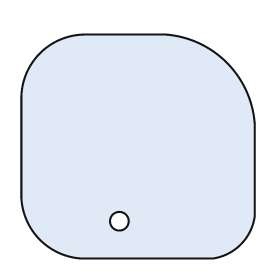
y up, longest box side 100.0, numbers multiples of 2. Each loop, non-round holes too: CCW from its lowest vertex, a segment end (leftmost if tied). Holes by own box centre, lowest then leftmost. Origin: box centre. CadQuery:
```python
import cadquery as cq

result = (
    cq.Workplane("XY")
    .moveTo(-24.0, -48.0)
    .lineTo(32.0, -48.0)
    .threePointArc((44.0, -42.0), (50.0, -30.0))
    .lineTo(50.0, 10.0)
    .threePointArc((38.0, 36.0), (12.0, 48.0))
    .lineTo(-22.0, 48.0)
    .threePointArc((-42.0, 40.0), (-50.0, 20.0))
    .lineTo(-50.0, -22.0)
    .threePointArc((-42.0, -40.0), (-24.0, -48.0))
    .close()
    .moveTo(-8.0, -32.0)
    .circle(4.0)
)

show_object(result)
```